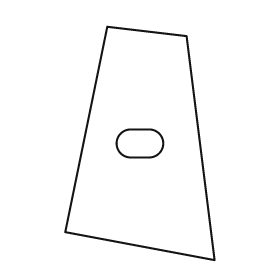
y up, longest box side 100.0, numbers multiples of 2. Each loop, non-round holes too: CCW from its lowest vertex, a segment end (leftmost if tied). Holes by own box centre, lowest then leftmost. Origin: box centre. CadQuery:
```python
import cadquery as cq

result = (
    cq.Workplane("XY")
    .moveTo(32.0, -50.0)
    .lineTo(20.0, 46.0)
    .lineTo(-14.0, 50.0)
    .lineTo(-32.0, -38.0)
    .close()
    .moveTo(-4.0, -6.0)
    .lineTo(4.0, -6.0)
    .threePointArc((10.0, 0.0), (4.0, 6.0))
    .lineTo(-4.0, 6.0)
    .threePointArc((-10.0, 0.0), (-4.0, -6.0))
    .close()
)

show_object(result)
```